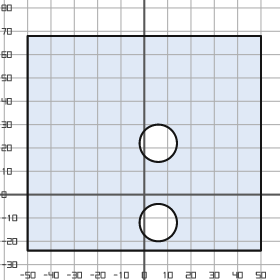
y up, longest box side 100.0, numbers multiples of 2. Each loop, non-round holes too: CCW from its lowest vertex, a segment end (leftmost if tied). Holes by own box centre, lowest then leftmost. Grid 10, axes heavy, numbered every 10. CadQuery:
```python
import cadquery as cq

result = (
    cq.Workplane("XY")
    .moveTo(-50.0, -24.0)
    .lineTo(50.0, -24.0)
    .lineTo(50.0, 68.0)
    .lineTo(-50.0, 68.0)
    .close()
    .moveTo(6.0, -12.0)
    .circle(8.0)
    .moveTo(6.0, 22.0)
    .circle(8.0)
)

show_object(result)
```